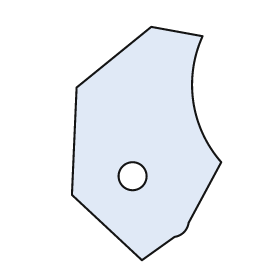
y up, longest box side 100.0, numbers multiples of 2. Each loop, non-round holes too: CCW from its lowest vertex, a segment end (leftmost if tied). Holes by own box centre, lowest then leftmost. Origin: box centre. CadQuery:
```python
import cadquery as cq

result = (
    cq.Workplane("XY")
    .moveTo(-2.0, -50.0)
    .lineTo(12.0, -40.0)
    .threePointArc((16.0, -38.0), (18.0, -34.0))
    .lineTo(32.0, -8.0)
    .threePointArc((20.0, 18.0), (24.0, 46.0))
    .lineTo(2.0, 50.0)
    .lineTo(-30.0, 24.0)
    .lineTo(-32.0, -22.0)
    .close()
    .moveTo(-6.0, -14.0)
    .circle(6.0)
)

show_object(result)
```